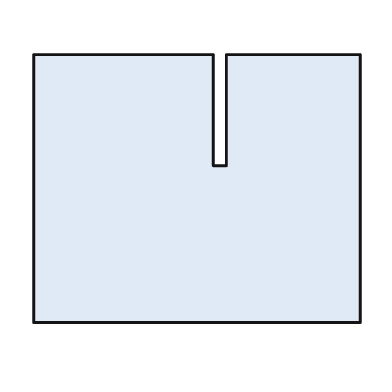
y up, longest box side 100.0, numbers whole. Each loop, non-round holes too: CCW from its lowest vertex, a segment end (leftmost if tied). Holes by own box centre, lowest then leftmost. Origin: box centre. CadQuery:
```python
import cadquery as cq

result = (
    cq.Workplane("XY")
    .moveTo(-50.0, -41.0)
    .lineTo(50.0, -41.0)
    .lineTo(50.0, 41.0)
    .lineTo(9.0, 41.0)
    .lineTo(9.0, 7.0)
    .lineTo(5.0, 7.0)
    .lineTo(5.0, 41.0)
    .lineTo(-50.0, 41.0)
    .close()
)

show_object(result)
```